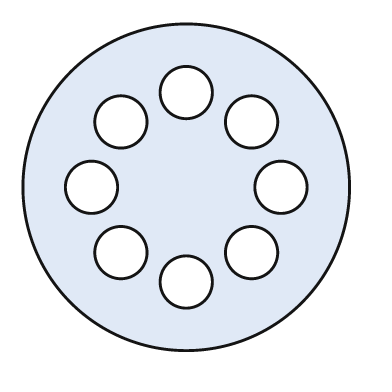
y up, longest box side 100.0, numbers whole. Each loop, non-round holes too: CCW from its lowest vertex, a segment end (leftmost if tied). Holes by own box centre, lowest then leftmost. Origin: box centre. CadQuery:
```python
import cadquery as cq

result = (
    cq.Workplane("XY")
    .moveTo(0.0, 0.0)
    .circle(50.0)
    .moveTo(0.0, -29.0)
    .circle(8.0)
    .moveTo(-20.0, -20.0)
    .circle(8.0)
    .moveTo(20.0, -20.0)
    .circle(8.0)
    .moveTo(-29.0, 0.0)
    .circle(8.0)
    .moveTo(29.0, 0.0)
    .circle(8.0)
    .moveTo(-20.0, 20.0)
    .circle(8.0)
    .moveTo(20.0, 20.0)
    .circle(8.0)
    .moveTo(0.0, 29.0)
    .circle(8.0)
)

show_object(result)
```